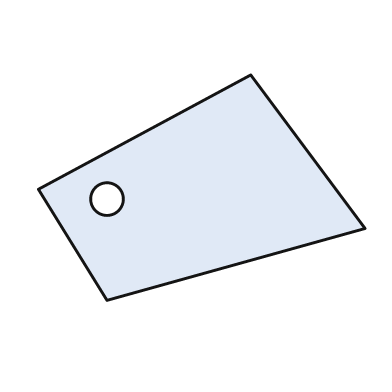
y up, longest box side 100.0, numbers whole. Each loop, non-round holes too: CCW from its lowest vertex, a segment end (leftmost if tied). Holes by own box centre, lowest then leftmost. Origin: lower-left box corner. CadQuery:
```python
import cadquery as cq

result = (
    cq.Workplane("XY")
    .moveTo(21.0, 0.0)
    .lineTo(100.0, 22.0)
    .lineTo(65.0, 69.0)
    .lineTo(0.0, 34.0)
    .close()
    .moveTo(21.0, 31.0)
    .circle(5.0)
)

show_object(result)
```